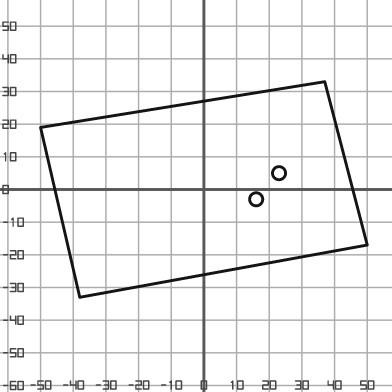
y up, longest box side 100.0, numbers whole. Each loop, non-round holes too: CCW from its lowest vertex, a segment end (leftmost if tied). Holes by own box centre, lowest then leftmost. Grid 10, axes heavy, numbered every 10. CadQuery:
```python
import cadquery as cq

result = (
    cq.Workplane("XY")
    .moveTo(-38.0, -33.0)
    .lineTo(50.0, -17.0)
    .lineTo(37.0, 33.0)
    .lineTo(-50.0, 19.0)
    .close()
    .moveTo(16.0, -3.0)
    .circle(2.0)
    .moveTo(23.0, 5.0)
    .circle(2.0)
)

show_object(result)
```